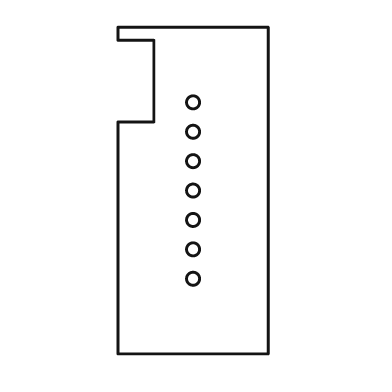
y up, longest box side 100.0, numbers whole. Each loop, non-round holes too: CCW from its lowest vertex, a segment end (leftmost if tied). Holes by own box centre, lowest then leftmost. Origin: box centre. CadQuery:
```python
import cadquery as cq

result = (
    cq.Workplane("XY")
    .moveTo(-23.0, -50.0)
    .lineTo(23.0, -50.0)
    .lineTo(23.0, 50.0)
    .lineTo(-23.0, 50.0)
    .lineTo(-23.0, 46.0)
    .lineTo(-12.0, 46.0)
    .lineTo(-12.0, 21.0)
    .lineTo(-23.0, 21.0)
    .close()
    .moveTo(0.0, -27.0)
    .circle(2.0)
    .moveTo(0.0, -18.0)
    .circle(2.0)
    .moveTo(0.0, -9.0)
    .circle(2.0)
    .moveTo(0.0, 0.0)
    .circle(2.0)
    .moveTo(0.0, 9.0)
    .circle(2.0)
    .moveTo(0.0, 18.0)
    .circle(2.0)
    .moveTo(0.0, 27.0)
    .circle(2.0)
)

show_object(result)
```